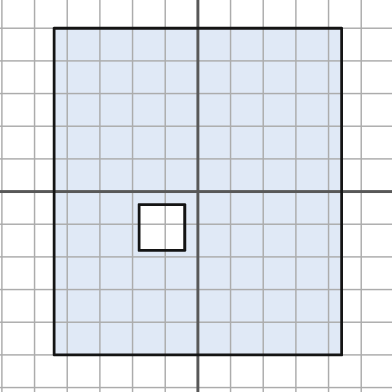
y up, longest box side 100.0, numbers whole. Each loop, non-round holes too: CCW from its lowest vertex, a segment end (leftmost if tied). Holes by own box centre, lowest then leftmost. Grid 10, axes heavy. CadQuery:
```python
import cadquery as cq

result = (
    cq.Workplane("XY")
    .moveTo(-44.0, -50.0)
    .lineTo(44.0, -50.0)
    .lineTo(44.0, 50.0)
    .lineTo(-44.0, 50.0)
    .close()
    .moveTo(-18.0, -18.0)
    .lineTo(-4.0, -18.0)
    .lineTo(-4.0, -4.0)
    .lineTo(-18.0, -4.0)
    .close()
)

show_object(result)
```